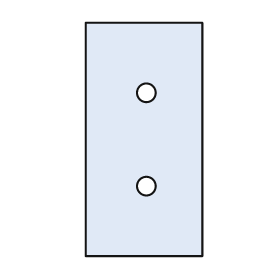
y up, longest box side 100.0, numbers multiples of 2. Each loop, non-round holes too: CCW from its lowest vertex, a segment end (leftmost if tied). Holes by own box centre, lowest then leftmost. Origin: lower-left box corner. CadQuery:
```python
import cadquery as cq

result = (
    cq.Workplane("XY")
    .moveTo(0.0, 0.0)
    .lineTo(50.0, 0.0)
    .lineTo(50.0, 100.0)
    .lineTo(0.0, 100.0)
    .close()
    .moveTo(26.0, 30.0)
    .circle(4.0)
    .moveTo(26.0, 70.0)
    .circle(4.0)
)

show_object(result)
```